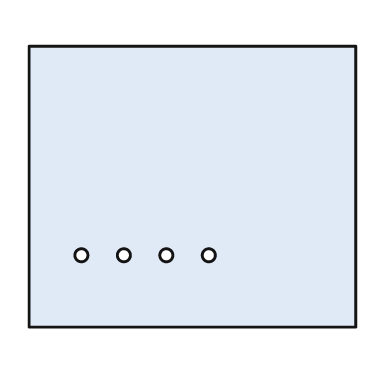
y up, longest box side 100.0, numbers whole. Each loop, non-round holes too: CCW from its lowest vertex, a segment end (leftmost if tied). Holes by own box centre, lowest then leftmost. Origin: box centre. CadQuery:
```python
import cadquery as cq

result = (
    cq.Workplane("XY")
    .moveTo(-50.0, -43.0)
    .lineTo(50.0, -43.0)
    .lineTo(50.0, 43.0)
    .lineTo(-50.0, 43.0)
    .close()
    .moveTo(-34.0, -21.0)
    .circle(2.0)
    .moveTo(-21.0, -21.0)
    .circle(2.0)
    .moveTo(-8.0, -21.0)
    .circle(2.0)
    .moveTo(5.0, -21.0)
    .circle(2.0)
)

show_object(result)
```